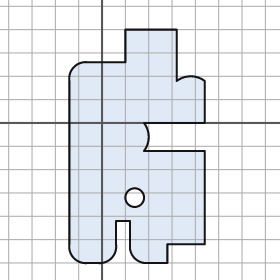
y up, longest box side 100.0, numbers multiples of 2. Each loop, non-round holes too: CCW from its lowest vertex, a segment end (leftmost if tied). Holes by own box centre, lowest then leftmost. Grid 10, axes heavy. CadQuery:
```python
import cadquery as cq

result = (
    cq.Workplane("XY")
    .moveTo(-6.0, -60.0)
    .lineTo(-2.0, -60.0)
    .threePointArc((4.0, -58.0), (6.0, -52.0))
    .lineTo(6.0, -42.0)
    .lineTo(12.0, -42.0)
    .lineTo(12.0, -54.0)
    .threePointArc((14.0, -58.0), (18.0, -60.0))
    .lineTo(28.0, -60.0)
    .lineTo(28.0, -52.0)
    .lineTo(44.0, -52.0)
    .lineTo(44.0, -12.0)
    .lineTo(18.0, -12.0)
    .threePointArc((20.0, -6.0), (18.0, 0.0))
    .lineTo(44.0, 0.0)
    .lineTo(44.0, 18.0)
    .threePointArc((38.0, 20.0), (32.0, 18.0))
    .lineTo(32.0, 40.0)
    .lineTo(10.0, 40.0)
    .lineTo(10.0, 26.0)
    .lineTo(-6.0, 26.0)
    .threePointArc((-12.0, 24.0), (-14.0, 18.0))
    .lineTo(-14.0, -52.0)
    .threePointArc((-12.0, -58.0), (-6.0, -60.0))
    .close()
    .moveTo(14.0, -32.0)
    .circle(4.0)
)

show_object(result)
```